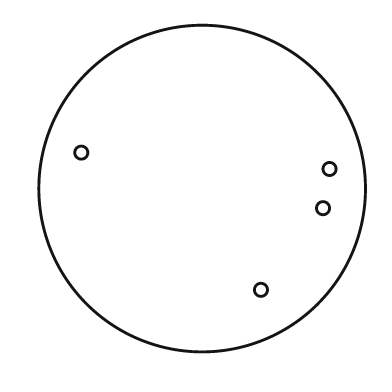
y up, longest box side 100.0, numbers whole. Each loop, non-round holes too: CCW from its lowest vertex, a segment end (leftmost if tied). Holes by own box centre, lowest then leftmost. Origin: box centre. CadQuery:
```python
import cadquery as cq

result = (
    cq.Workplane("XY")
    .moveTo(0.0, 0.0)
    .circle(50.0)
    .moveTo(18.0, -31.0)
    .circle(2.0)
    .moveTo(37.0, -6.0)
    .circle(2.0)
    .moveTo(39.0, 6.0)
    .circle(2.0)
    .moveTo(-37.0, 11.0)
    .circle(2.0)
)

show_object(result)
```